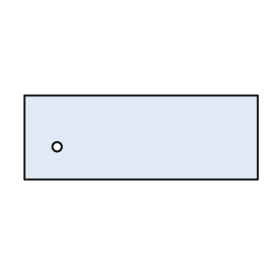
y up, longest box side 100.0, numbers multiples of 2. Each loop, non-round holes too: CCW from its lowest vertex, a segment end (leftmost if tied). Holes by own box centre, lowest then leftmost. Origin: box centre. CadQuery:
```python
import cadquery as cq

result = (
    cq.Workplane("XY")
    .moveTo(-50.0, -18.0)
    .lineTo(50.0, -18.0)
    .lineTo(50.0, 18.0)
    .lineTo(-50.0, 18.0)
    .close()
    .moveTo(-36.0, -4.0)
    .circle(2.0)
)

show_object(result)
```